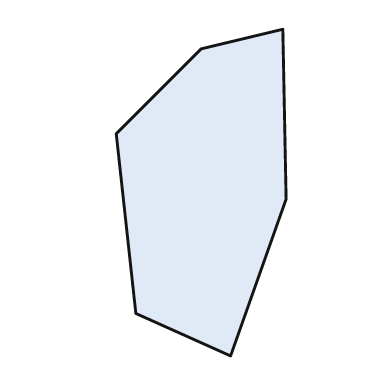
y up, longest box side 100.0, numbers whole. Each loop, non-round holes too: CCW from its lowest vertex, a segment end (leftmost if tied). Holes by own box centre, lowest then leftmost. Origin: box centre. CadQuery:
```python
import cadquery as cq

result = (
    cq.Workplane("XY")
    .moveTo(9.0, -50.0)
    .lineTo(26.0, -2.0)
    .lineTo(25.0, 50.0)
    .lineTo(0.0, 44.0)
    .lineTo(-26.0, 18.0)
    .lineTo(-20.0, -37.0)
    .close()
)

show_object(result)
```